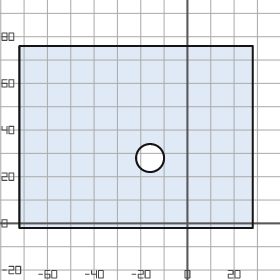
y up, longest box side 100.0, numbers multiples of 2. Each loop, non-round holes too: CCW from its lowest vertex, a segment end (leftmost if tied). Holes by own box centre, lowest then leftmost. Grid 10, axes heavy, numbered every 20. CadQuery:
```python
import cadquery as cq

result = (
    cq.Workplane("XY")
    .moveTo(-72.0, -2.0)
    .lineTo(28.0, -2.0)
    .lineTo(28.0, 76.0)
    .lineTo(-72.0, 76.0)
    .close()
    .moveTo(-16.0, 28.0)
    .circle(6.0)
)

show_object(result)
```